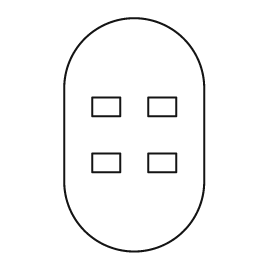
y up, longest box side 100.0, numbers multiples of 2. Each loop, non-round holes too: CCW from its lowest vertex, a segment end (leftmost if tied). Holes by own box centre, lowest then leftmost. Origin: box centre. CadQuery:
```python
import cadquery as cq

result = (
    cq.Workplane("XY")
    .moveTo(-30.0, -20.0)
    .threePointArc((0.0, -50.0), (30.0, -20.0))
    .lineTo(30.0, 20.0)
    .threePointArc((0.0, 50.0), (-30.0, 20.0))
    .close()
    .moveTo(-18.0, -16.0)
    .lineTo(-6.0, -16.0)
    .lineTo(-6.0, -8.0)
    .lineTo(-18.0, -8.0)
    .close()
    .moveTo(6.0, -16.0)
    .lineTo(18.0, -16.0)
    .lineTo(18.0, -8.0)
    .lineTo(6.0, -8.0)
    .close()
    .moveTo(-18.0, 8.0)
    .lineTo(-6.0, 8.0)
    .lineTo(-6.0, 16.0)
    .lineTo(-18.0, 16.0)
    .close()
    .moveTo(6.0, 8.0)
    .lineTo(18.0, 8.0)
    .lineTo(18.0, 16.0)
    .lineTo(6.0, 16.0)
    .close()
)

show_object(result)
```